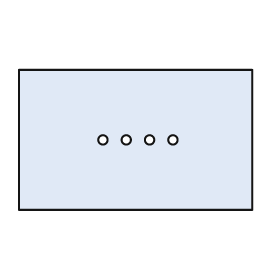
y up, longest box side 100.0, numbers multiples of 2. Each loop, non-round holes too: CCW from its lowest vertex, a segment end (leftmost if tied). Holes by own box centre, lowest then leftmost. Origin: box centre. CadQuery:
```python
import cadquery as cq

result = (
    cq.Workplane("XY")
    .moveTo(-50.0, -30.0)
    .lineTo(50.0, -30.0)
    .lineTo(50.0, 30.0)
    .lineTo(-50.0, 30.0)
    .close()
    .moveTo(-14.0, 0.0)
    .circle(2.0)
    .moveTo(-4.0, 0.0)
    .circle(2.0)
    .moveTo(6.0, 0.0)
    .circle(2.0)
    .moveTo(16.0, 0.0)
    .circle(2.0)
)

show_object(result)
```